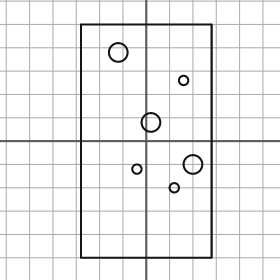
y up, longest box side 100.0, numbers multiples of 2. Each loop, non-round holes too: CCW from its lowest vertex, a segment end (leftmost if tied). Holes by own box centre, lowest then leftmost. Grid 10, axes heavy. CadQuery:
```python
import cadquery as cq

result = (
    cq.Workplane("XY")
    .moveTo(-28.0, -50.0)
    .lineTo(28.0, -50.0)
    .lineTo(28.0, 50.0)
    .lineTo(-28.0, 50.0)
    .close()
    .moveTo(12.0, -20.0)
    .circle(2.0)
    .moveTo(-4.0, -12.0)
    .circle(2.0)
    .moveTo(20.0, -10.0)
    .circle(4.0)
    .moveTo(2.0, 8.0)
    .circle(4.0)
    .moveTo(16.0, 26.0)
    .circle(2.0)
    .moveTo(-12.0, 38.0)
    .circle(4.0)
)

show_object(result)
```